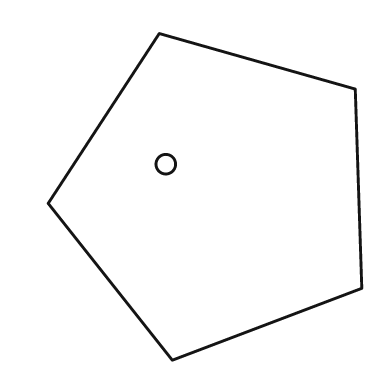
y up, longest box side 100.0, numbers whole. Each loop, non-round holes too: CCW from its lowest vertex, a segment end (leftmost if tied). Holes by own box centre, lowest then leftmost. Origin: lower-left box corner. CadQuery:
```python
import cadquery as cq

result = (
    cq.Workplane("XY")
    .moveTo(38.0, 0.0)
    .lineTo(96.0, 22.0)
    .lineTo(94.0, 83.0)
    .lineTo(34.0, 100.0)
    .lineTo(0.0, 48.0)
    .close()
    .moveTo(36.0, 60.0)
    .circle(3.0)
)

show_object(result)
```